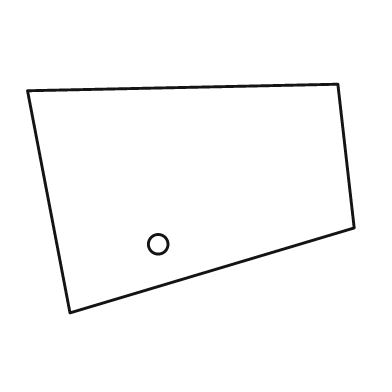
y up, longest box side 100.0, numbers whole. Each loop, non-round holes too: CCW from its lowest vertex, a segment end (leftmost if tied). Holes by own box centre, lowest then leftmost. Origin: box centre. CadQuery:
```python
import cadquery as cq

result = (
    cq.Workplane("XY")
    .moveTo(-37.0, -35.0)
    .lineTo(50.0, -9.0)
    .lineTo(45.0, 35.0)
    .lineTo(-50.0, 33.0)
    .close()
    .moveTo(-10.0, -14.0)
    .circle(3.0)
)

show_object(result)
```